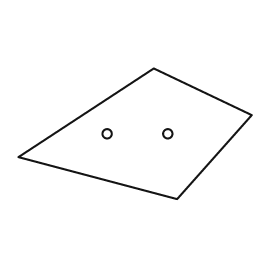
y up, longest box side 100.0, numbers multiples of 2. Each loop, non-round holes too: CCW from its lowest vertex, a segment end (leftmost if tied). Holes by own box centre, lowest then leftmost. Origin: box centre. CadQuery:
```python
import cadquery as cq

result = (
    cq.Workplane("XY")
    .moveTo(18.0, -28.0)
    .lineTo(50.0, 8.0)
    .lineTo(8.0, 28.0)
    .lineTo(-50.0, -10.0)
    .close()
    .moveTo(-12.0, 0.0)
    .circle(2.0)
    .moveTo(14.0, 0.0)
    .circle(2.0)
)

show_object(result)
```